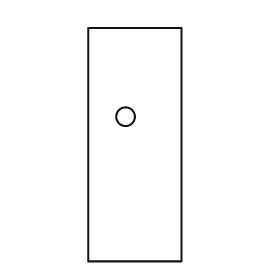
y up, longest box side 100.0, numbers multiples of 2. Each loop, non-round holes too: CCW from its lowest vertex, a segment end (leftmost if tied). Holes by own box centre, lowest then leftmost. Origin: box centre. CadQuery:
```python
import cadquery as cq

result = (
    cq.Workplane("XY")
    .moveTo(-20.0, -50.0)
    .lineTo(20.0, -50.0)
    .lineTo(20.0, 50.0)
    .lineTo(-20.0, 50.0)
    .close()
    .moveTo(-4.0, 12.0)
    .circle(4.0)
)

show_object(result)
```